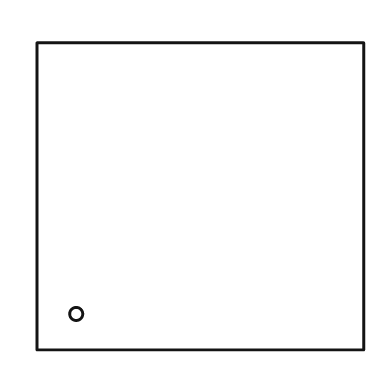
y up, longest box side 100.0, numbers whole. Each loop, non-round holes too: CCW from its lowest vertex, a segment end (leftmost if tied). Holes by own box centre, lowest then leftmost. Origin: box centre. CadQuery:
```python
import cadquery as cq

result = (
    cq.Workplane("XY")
    .moveTo(-50.0, -47.0)
    .lineTo(50.0, -47.0)
    .lineTo(50.0, 47.0)
    .lineTo(-50.0, 47.0)
    .close()
    .moveTo(-38.0, -36.0)
    .circle(2.0)
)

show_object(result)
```